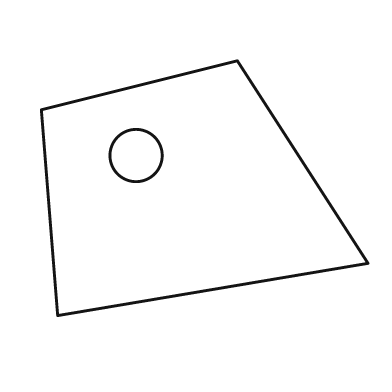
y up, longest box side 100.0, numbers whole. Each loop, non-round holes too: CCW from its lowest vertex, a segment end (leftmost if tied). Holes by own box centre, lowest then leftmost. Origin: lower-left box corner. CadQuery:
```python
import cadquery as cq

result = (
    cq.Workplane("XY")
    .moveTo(5.0, 0.0)
    .lineTo(100.0, 16.0)
    .lineTo(60.0, 78.0)
    .lineTo(0.0, 63.0)
    .close()
    .moveTo(29.0, 49.0)
    .circle(8.0)
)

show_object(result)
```